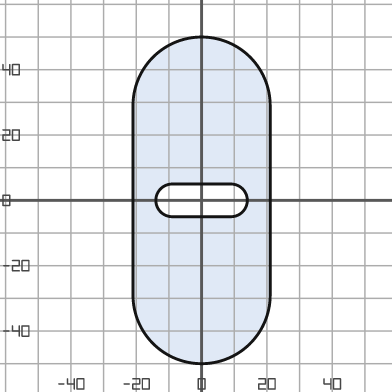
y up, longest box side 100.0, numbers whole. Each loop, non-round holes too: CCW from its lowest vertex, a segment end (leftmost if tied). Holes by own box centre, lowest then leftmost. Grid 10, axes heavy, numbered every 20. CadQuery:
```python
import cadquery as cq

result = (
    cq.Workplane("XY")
    .moveTo(-21.0, -29.0)
    .threePointArc((0.0, -50.0), (21.0, -29.0))
    .lineTo(21.0, 29.0)
    .threePointArc((0.0, 50.0), (-21.0, 29.0))
    .close()
    .moveTo(-9.0, -5.0)
    .lineTo(9.0, -5.0)
    .threePointArc((14.0, 0.0), (9.0, 5.0))
    .lineTo(-9.0, 5.0)
    .threePointArc((-14.0, 0.0), (-9.0, -5.0))
    .close()
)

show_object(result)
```